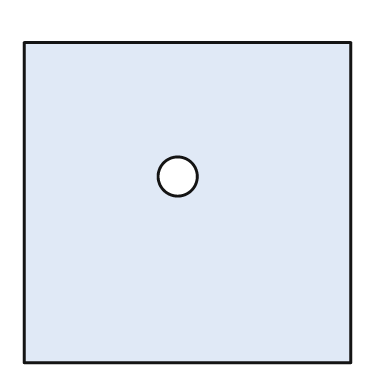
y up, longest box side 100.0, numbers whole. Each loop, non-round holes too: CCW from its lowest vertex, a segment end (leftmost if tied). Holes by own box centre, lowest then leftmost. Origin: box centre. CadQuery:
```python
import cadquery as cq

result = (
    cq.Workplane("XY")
    .moveTo(-50.0, -49.0)
    .lineTo(50.0, -49.0)
    .lineTo(50.0, 49.0)
    .lineTo(-50.0, 49.0)
    .close()
    .moveTo(-3.0, 8.0)
    .circle(6.0)
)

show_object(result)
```